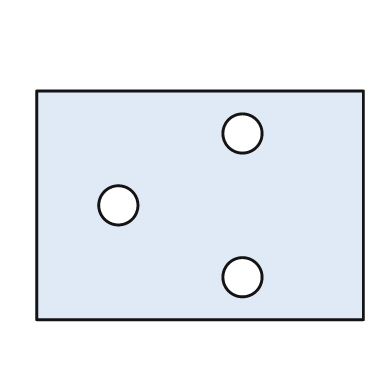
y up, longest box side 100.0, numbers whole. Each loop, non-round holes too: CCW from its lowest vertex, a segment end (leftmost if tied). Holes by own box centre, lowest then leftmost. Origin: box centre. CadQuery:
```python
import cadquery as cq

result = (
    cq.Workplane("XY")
    .moveTo(-50.0, -35.0)
    .lineTo(50.0, -35.0)
    .lineTo(50.0, 35.0)
    .lineTo(-50.0, 35.0)
    .close()
    .moveTo(13.0, -22.0)
    .circle(6.0)
    .moveTo(-25.0, 0.0)
    .circle(6.0)
    .moveTo(13.0, 22.0)
    .circle(6.0)
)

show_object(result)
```